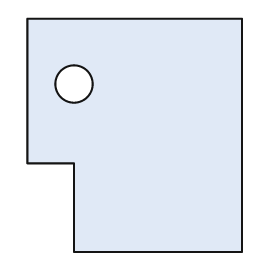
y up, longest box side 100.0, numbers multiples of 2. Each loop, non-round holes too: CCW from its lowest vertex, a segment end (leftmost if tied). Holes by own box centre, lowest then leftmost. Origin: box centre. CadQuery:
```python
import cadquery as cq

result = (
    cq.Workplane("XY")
    .moveTo(-26.0, -50.0)
    .lineTo(46.0, -50.0)
    .lineTo(46.0, 50.0)
    .lineTo(-46.0, 50.0)
    .lineTo(-46.0, -12.0)
    .lineTo(-26.0, -12.0)
    .close()
    .moveTo(-26.0, 22.0)
    .circle(8.0)
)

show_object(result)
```